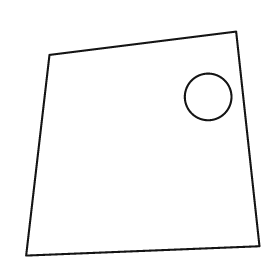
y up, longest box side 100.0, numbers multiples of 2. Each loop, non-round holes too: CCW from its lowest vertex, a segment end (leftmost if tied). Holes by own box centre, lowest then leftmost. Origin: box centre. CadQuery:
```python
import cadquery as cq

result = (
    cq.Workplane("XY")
    .moveTo(-50.0, -48.0)
    .lineTo(50.0, -44.0)
    .lineTo(40.0, 48.0)
    .lineTo(-40.0, 38.0)
    .close()
    .moveTo(28.0, 20.0)
    .circle(10.0)
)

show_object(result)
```